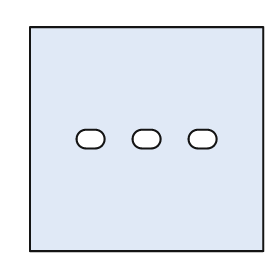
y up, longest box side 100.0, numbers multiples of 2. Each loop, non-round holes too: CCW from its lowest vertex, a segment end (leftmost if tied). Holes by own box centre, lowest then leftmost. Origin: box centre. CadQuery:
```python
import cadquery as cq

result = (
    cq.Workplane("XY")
    .moveTo(-50.0, -48.0)
    .lineTo(50.0, -48.0)
    .lineTo(50.0, 48.0)
    .lineTo(-50.0, 48.0)
    .close()
    .moveTo(-26.0, -4.0)
    .lineTo(-22.0, -4.0)
    .threePointArc((-18.0, 0.0), (-22.0, 4.0))
    .lineTo(-26.0, 4.0)
    .threePointArc((-30.0, 0.0), (-26.0, -4.0))
    .close()
    .moveTo(-2.0, -4.0)
    .lineTo(2.0, -4.0)
    .threePointArc((6.0, 0.0), (2.0, 4.0))
    .lineTo(-2.0, 4.0)
    .threePointArc((-6.0, 0.0), (-2.0, -4.0))
    .close()
    .moveTo(22.0, -4.0)
    .lineTo(26.0, -4.0)
    .threePointArc((30.0, 0.0), (26.0, 4.0))
    .lineTo(22.0, 4.0)
    .threePointArc((18.0, 0.0), (22.0, -4.0))
    .close()
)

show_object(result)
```